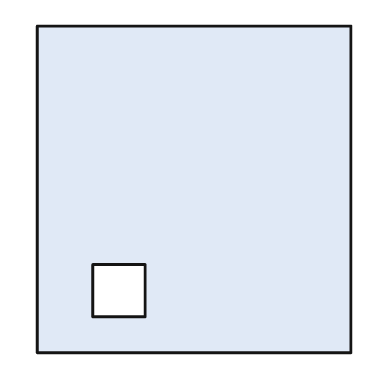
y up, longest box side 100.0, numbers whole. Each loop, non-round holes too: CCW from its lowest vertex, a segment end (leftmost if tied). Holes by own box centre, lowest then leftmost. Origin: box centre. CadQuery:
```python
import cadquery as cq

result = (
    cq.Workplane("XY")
    .moveTo(-48.0, -50.0)
    .lineTo(48.0, -50.0)
    .lineTo(48.0, 50.0)
    .lineTo(-48.0, 50.0)
    .close()
    .moveTo(-31.0, -39.0)
    .lineTo(-15.0, -39.0)
    .lineTo(-15.0, -23.0)
    .lineTo(-31.0, -23.0)
    .close()
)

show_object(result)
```